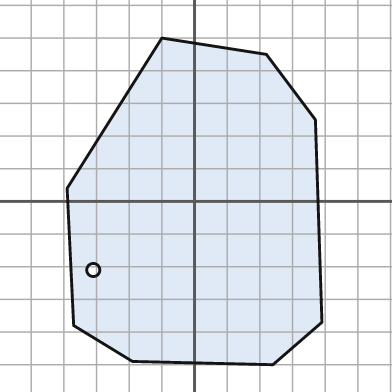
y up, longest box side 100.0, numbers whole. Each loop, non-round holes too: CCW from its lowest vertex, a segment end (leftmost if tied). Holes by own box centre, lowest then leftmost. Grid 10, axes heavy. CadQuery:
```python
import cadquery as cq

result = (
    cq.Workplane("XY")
    .moveTo(24.0, -50.0)
    .lineTo(39.0, -37.0)
    .lineTo(37.0, 25.0)
    .lineTo(22.0, 45.0)
    .lineTo(-10.0, 50.0)
    .lineTo(-39.0, 4.0)
    .lineTo(-37.0, -38.0)
    .lineTo(-19.0, -49.0)
    .close()
    .moveTo(-31.0, -21.0)
    .circle(2.0)
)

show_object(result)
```